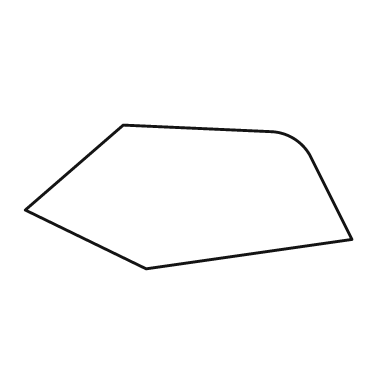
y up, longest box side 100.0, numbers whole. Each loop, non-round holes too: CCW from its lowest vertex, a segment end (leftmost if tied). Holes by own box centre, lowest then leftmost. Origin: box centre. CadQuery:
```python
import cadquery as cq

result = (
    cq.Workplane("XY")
    .moveTo(-13.0, -22.0)
    .lineTo(50.0, -13.0)
    .lineTo(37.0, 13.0)
    .threePointArc((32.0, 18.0), (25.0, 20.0))
    .lineTo(-20.0, 22.0)
    .lineTo(-50.0, -4.0)
    .close()
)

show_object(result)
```